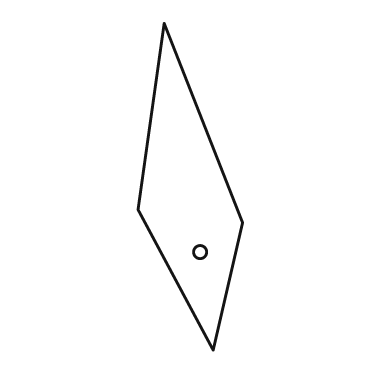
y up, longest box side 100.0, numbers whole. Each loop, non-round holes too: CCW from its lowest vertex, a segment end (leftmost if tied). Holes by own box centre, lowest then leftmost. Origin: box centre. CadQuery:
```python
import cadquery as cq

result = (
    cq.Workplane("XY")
    .moveTo(7.0, -50.0)
    .lineTo(16.0, -11.0)
    .lineTo(-8.0, 50.0)
    .lineTo(-16.0, -7.0)
    .close()
    .moveTo(3.0, -20.0)
    .circle(2.0)
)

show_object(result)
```